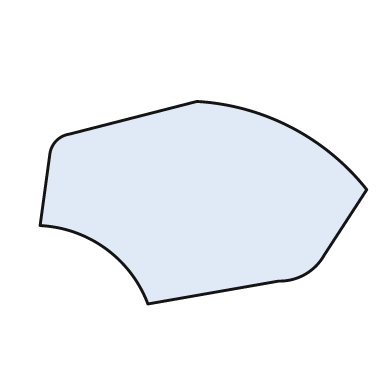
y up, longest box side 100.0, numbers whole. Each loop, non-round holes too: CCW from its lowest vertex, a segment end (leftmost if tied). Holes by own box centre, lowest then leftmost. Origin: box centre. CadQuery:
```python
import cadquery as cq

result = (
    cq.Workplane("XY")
    .moveTo(-17.0, -31.0)
    .lineTo(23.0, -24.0)
    .threePointArc((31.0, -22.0), (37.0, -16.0))
    .lineTo(50.0, 4.0)
    .threePointArc((27.0, 23.0), (-2.0, 31.0))
    .lineTo(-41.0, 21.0)
    .threePointArc((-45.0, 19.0), (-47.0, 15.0))
    .lineTo(-50.0, -7.0)
    .threePointArc((-30.0, -14.0), (-17.0, -31.0))
    .close()
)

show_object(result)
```